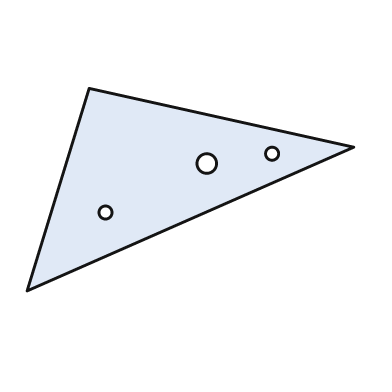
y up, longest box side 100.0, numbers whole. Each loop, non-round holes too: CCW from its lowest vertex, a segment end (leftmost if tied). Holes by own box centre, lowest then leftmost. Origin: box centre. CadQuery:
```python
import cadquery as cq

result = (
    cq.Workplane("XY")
    .moveTo(-50.0, -31.0)
    .lineTo(50.0, 13.0)
    .lineTo(-31.0, 31.0)
    .close()
    .moveTo(-26.0, -7.0)
    .circle(2.0)
    .moveTo(5.0, 8.0)
    .circle(3.0)
    .moveTo(25.0, 11.0)
    .circle(2.0)
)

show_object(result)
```